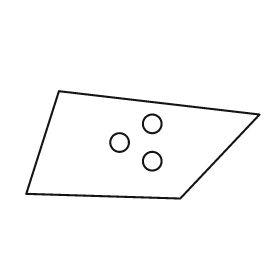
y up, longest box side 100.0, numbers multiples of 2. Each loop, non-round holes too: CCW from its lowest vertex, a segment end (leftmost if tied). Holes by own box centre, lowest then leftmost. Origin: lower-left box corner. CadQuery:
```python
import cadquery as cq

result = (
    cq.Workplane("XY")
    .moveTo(66.0, 0.0)
    .lineTo(100.0, 36.0)
    .lineTo(14.0, 46.0)
    .lineTo(0.0, 2.0)
    .close()
    .moveTo(54.0, 16.0)
    .circle(4.0)
    .moveTo(40.0, 24.0)
    .circle(4.0)
    .moveTo(54.0, 32.0)
    .circle(4.0)
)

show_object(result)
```